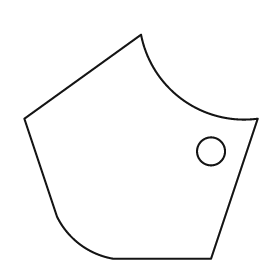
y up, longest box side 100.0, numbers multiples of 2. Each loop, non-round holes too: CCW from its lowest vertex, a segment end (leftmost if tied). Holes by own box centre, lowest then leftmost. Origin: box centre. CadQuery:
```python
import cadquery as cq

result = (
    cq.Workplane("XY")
    .moveTo(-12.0, -48.0)
    .lineTo(30.0, -48.0)
    .lineTo(50.0, 12.0)
    .threePointArc((18.0, 20.0), (0.0, 48.0))
    .lineTo(-50.0, 12.0)
    .lineTo(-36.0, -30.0)
    .threePointArc((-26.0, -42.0), (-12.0, -48.0))
    .close()
    .moveTo(30.0, -2.0)
    .circle(6.0)
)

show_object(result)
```